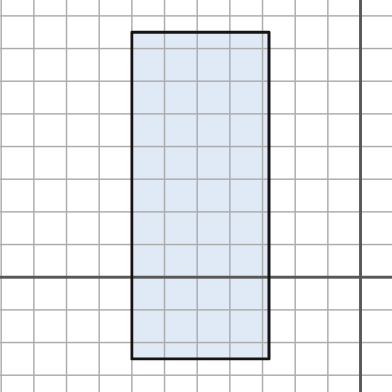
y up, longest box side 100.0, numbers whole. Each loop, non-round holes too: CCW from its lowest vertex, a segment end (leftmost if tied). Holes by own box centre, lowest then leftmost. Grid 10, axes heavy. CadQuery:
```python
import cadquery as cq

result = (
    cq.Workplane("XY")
    .moveTo(-70.0, -25.0)
    .lineTo(-28.0, -25.0)
    .lineTo(-28.0, 75.0)
    .lineTo(-70.0, 75.0)
    .close()
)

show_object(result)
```